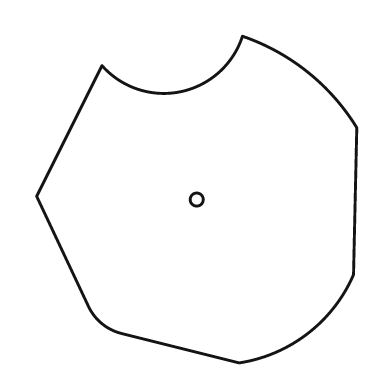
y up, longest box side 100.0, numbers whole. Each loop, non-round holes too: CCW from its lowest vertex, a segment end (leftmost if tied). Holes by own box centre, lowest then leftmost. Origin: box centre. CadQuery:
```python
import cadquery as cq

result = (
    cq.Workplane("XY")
    .moveTo(13.0, -50.0)
    .threePointArc((34.0, -41.0), (48.0, -23.0))
    .lineTo(49.0, 22.0)
    .threePointArc((34.0, 39.0), (14.0, 50.0))
    .threePointArc((-5.0, 33.0), (-29.0, 41.0))
    .lineTo(-49.0, 1.0)
    .lineTo(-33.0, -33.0)
    .threePointArc((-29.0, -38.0), (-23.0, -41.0))
    .close()
    .moveTo(0.0, 0.0)
    .circle(2.0)
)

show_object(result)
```